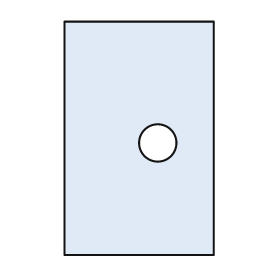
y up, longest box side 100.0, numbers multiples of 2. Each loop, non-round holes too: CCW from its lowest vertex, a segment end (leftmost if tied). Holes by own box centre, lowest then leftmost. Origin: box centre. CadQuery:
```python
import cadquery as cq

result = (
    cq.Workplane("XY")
    .moveTo(-32.0, -50.0)
    .lineTo(32.0, -50.0)
    .lineTo(32.0, 50.0)
    .lineTo(-32.0, 50.0)
    .close()
    .moveTo(8.0, -2.0)
    .circle(8.0)
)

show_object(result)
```